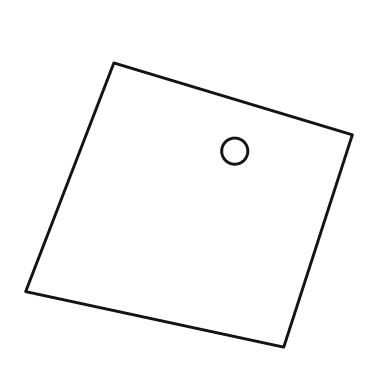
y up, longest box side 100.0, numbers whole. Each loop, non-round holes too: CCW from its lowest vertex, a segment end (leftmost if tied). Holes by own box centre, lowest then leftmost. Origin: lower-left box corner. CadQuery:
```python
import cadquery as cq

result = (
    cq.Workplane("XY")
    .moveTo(79.0, 0.0)
    .lineTo(100.0, 65.0)
    .lineTo(27.0, 87.0)
    .lineTo(0.0, 17.0)
    .close()
    .moveTo(64.0, 60.0)
    .circle(4.0)
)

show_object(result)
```